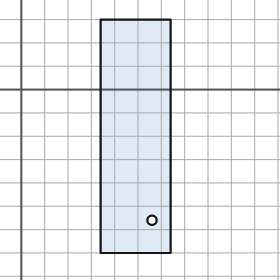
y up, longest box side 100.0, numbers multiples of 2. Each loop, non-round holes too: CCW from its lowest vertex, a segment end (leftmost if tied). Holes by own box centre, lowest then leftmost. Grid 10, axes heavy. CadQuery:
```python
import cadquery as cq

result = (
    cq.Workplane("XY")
    .moveTo(34.0, -70.0)
    .lineTo(64.0, -70.0)
    .lineTo(64.0, 30.0)
    .lineTo(34.0, 30.0)
    .close()
    .moveTo(56.0, -56.0)
    .circle(2.0)
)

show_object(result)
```